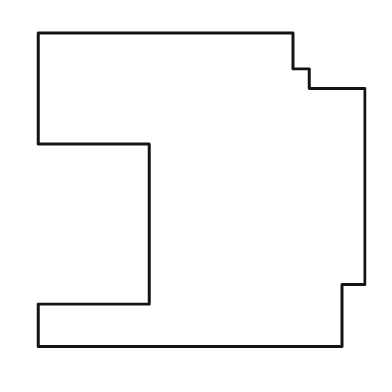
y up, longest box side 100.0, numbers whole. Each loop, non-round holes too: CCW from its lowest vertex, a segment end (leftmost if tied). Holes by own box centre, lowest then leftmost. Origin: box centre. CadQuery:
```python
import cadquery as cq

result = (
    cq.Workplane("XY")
    .moveTo(-50.0, -48.0)
    .lineTo(43.0, -48.0)
    .lineTo(43.0, -29.0)
    .lineTo(50.0, -29.0)
    .lineTo(50.0, 31.0)
    .lineTo(33.0, 31.0)
    .lineTo(33.0, 37.0)
    .lineTo(28.0, 37.0)
    .lineTo(28.0, 48.0)
    .lineTo(-50.0, 48.0)
    .lineTo(-50.0, 14.0)
    .lineTo(-16.0, 14.0)
    .lineTo(-16.0, -35.0)
    .lineTo(-50.0, -35.0)
    .close()
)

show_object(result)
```